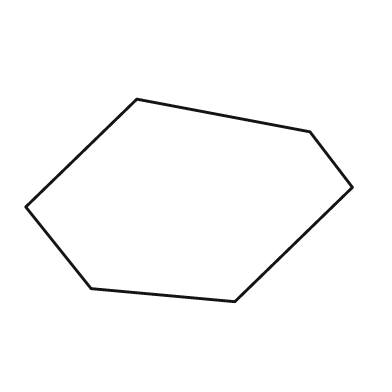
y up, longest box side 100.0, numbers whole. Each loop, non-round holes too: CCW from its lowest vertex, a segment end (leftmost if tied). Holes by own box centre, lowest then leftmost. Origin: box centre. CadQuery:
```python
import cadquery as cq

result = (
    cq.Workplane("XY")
    .moveTo(14.0, -31.0)
    .lineTo(50.0, 4.0)
    .lineTo(37.0, 21.0)
    .lineTo(-16.0, 31.0)
    .lineTo(-50.0, -2.0)
    .lineTo(-30.0, -27.0)
    .close()
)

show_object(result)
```